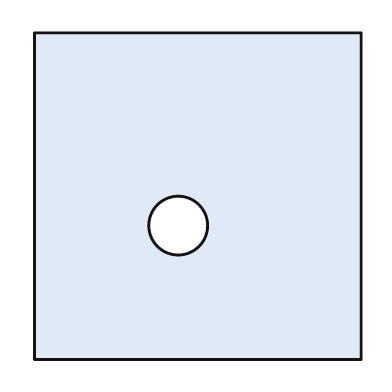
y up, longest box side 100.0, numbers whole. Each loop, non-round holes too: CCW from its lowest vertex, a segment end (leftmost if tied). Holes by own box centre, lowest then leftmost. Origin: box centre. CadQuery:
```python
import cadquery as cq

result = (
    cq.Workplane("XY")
    .moveTo(-50.0, -50.0)
    .lineTo(50.0, -50.0)
    .lineTo(50.0, 50.0)
    .lineTo(-50.0, 50.0)
    .close()
    .moveTo(-6.0, -9.0)
    .circle(9.0)
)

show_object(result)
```